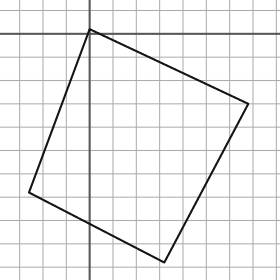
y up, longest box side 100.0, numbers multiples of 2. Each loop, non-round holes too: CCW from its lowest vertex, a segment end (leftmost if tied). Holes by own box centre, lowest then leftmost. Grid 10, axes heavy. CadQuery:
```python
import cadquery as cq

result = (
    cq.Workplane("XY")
    .moveTo(32.0, -98.0)
    .lineTo(68.0, -30.0)
    .lineTo(0.0, 2.0)
    .lineTo(-26.0, -68.0)
    .close()
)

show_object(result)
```